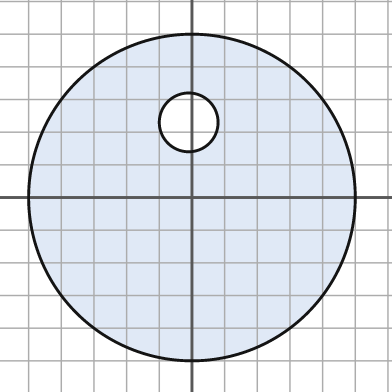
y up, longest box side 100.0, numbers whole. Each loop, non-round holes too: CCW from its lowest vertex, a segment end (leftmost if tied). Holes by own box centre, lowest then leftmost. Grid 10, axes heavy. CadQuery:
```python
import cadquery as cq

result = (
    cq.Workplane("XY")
    .moveTo(0.0, 0.0)
    .circle(50.0)
    .moveTo(-1.0, 23.0)
    .circle(9.0)
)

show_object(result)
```